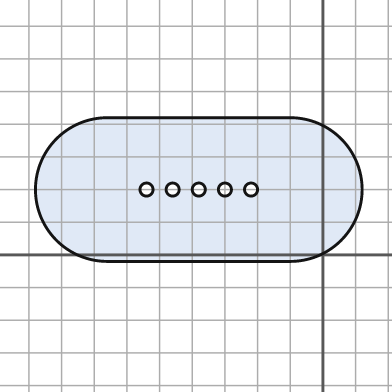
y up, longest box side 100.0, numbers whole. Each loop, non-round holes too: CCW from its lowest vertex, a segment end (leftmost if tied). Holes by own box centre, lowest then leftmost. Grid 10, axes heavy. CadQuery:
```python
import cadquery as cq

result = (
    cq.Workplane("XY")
    .moveTo(-66.0, -2.0)
    .lineTo(-10.0, -2.0)
    .threePointArc((12.0, 20.0), (-10.0, 42.0))
    .lineTo(-66.0, 42.0)
    .threePointArc((-88.0, 20.0), (-66.0, -2.0))
    .close()
    .moveTo(-54.0, 20.0)
    .circle(2.0)
    .moveTo(-46.0, 20.0)
    .circle(2.0)
    .moveTo(-38.0, 20.0)
    .circle(2.0)
    .moveTo(-30.0, 20.0)
    .circle(2.0)
    .moveTo(-22.0, 20.0)
    .circle(2.0)
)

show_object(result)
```